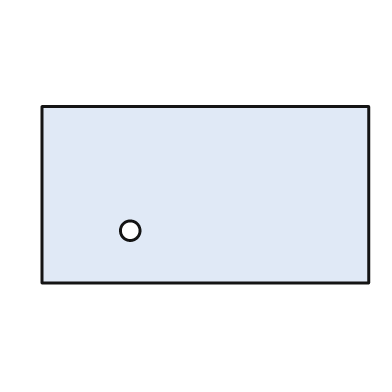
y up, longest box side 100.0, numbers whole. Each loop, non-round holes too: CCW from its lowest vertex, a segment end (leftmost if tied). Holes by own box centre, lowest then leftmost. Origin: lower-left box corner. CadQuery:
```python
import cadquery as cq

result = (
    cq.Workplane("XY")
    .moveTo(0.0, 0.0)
    .lineTo(100.0, 0.0)
    .lineTo(100.0, 54.0)
    .lineTo(0.0, 54.0)
    .close()
    .moveTo(27.0, 16.0)
    .circle(3.0)
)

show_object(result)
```